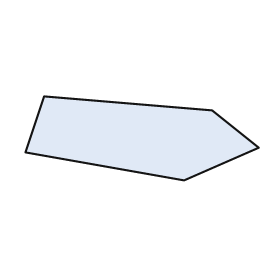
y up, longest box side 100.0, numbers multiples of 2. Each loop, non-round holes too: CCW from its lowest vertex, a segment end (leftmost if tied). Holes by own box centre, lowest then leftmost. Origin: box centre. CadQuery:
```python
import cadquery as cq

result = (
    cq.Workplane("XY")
    .moveTo(18.0, -18.0)
    .lineTo(50.0, -4.0)
    .lineTo(30.0, 12.0)
    .lineTo(-42.0, 18.0)
    .lineTo(-50.0, -6.0)
    .close()
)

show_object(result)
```